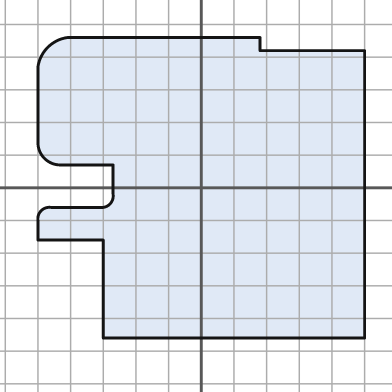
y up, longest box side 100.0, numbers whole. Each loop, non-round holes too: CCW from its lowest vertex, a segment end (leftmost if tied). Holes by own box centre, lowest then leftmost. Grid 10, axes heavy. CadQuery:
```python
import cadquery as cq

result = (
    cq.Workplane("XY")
    .moveTo(-30.0, -46.0)
    .lineTo(50.0, -46.0)
    .lineTo(50.0, 42.0)
    .lineTo(18.0, 42.0)
    .lineTo(18.0, 46.0)
    .lineTo(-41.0, 46.0)
    .threePointArc((-47.0, 43.0), (-50.0, 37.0))
    .lineTo(-50.0, 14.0)
    .threePointArc((-48.0, 9.0), (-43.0, 7.0))
    .lineTo(-27.0, 7.0)
    .lineTo(-27.0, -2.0)
    .threePointArc((-28.0, -5.0), (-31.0, -6.0))
    .lineTo(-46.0, -6.0)
    .threePointArc((-49.0, -7.0), (-50.0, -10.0))
    .lineTo(-50.0, -16.0)
    .lineTo(-30.0, -16.0)
    .close()
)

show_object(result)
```